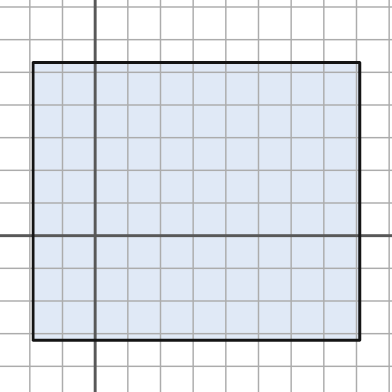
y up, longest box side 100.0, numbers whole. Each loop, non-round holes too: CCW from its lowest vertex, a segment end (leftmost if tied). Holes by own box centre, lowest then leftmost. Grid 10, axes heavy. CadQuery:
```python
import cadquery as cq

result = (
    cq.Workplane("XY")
    .moveTo(-19.0, -32.0)
    .lineTo(81.0, -32.0)
    .lineTo(81.0, 53.0)
    .lineTo(-19.0, 53.0)
    .close()
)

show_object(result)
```